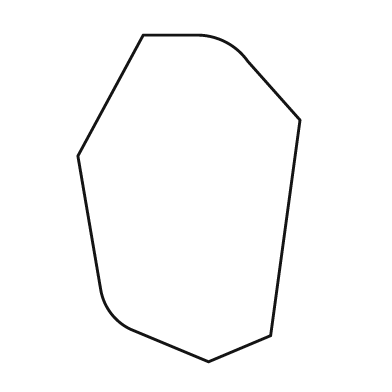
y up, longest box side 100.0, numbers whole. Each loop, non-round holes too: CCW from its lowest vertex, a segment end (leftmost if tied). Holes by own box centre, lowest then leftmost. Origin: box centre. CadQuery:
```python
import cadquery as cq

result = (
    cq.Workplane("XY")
    .moveTo(6.0, -50.0)
    .lineTo(25.0, -42.0)
    .lineTo(34.0, 24.0)
    .lineTo(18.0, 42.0)
    .threePointArc((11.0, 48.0), (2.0, 50.0))
    .lineTo(-14.0, 50.0)
    .lineTo(-34.0, 13.0)
    .lineTo(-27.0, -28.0)
    .threePointArc((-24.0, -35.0), (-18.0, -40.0))
    .close()
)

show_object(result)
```